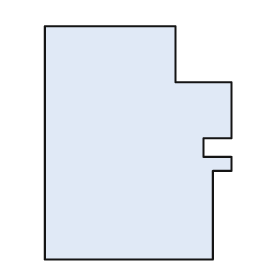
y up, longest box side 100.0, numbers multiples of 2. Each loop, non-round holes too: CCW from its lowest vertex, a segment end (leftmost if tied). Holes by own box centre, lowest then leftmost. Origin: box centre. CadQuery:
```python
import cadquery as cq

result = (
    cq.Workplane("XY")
    .moveTo(-40.0, -50.0)
    .lineTo(32.0, -50.0)
    .lineTo(32.0, -12.0)
    .lineTo(40.0, -12.0)
    .lineTo(40.0, -6.0)
    .lineTo(28.0, -6.0)
    .lineTo(28.0, 2.0)
    .lineTo(40.0, 2.0)
    .lineTo(40.0, 26.0)
    .lineTo(16.0, 26.0)
    .lineTo(16.0, 50.0)
    .lineTo(-40.0, 50.0)
    .close()
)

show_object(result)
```